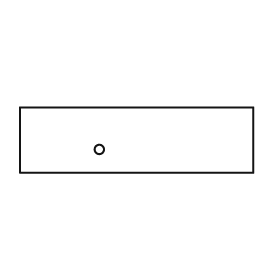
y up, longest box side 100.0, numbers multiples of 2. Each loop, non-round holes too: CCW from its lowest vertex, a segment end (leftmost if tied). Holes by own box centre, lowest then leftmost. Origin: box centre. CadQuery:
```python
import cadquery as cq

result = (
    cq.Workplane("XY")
    .moveTo(-50.0, -14.0)
    .lineTo(50.0, -14.0)
    .lineTo(50.0, 14.0)
    .lineTo(-50.0, 14.0)
    .close()
    .moveTo(-16.0, -4.0)
    .circle(2.0)
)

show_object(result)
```